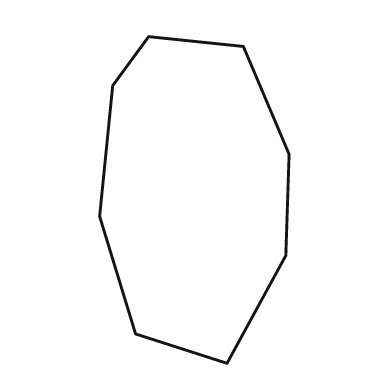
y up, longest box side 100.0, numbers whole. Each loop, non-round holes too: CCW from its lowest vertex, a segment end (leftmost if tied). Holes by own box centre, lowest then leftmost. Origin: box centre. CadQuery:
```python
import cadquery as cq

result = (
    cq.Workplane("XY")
    .moveTo(10.0, -50.0)
    .lineTo(28.0, -17.0)
    .lineTo(29.0, 14.0)
    .lineTo(15.0, 47.0)
    .lineTo(-14.0, 50.0)
    .lineTo(-25.0, 35.0)
    .lineTo(-29.0, -5.0)
    .lineTo(-18.0, -41.0)
    .close()
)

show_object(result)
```